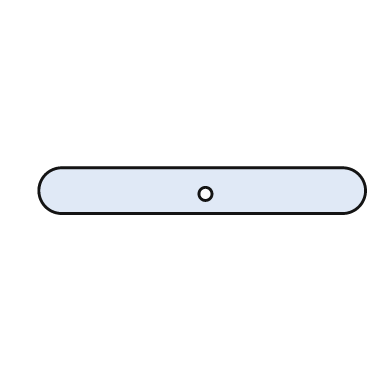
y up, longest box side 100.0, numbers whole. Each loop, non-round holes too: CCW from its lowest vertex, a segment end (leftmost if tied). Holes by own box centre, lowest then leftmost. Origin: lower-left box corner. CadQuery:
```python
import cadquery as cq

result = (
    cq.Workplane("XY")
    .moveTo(7.0, 0.0)
    .lineTo(93.0, 0.0)
    .threePointArc((100.0, 7.0), (93.0, 14.0))
    .lineTo(7.0, 14.0)
    .threePointArc((0.0, 7.0), (7.0, 0.0))
    .close()
    .moveTo(51.0, 6.0)
    .circle(2.0)
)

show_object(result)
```